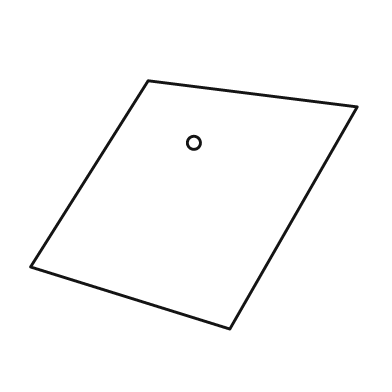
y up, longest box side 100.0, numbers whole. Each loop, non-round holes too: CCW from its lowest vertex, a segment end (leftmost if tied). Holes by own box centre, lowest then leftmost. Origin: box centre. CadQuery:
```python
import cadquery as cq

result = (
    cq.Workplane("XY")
    .moveTo(11.0, -38.0)
    .lineTo(50.0, 30.0)
    .lineTo(-14.0, 38.0)
    .lineTo(-50.0, -19.0)
    .close()
    .moveTo(0.0, 19.0)
    .circle(2.0)
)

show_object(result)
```